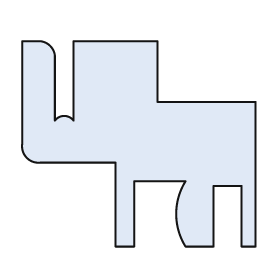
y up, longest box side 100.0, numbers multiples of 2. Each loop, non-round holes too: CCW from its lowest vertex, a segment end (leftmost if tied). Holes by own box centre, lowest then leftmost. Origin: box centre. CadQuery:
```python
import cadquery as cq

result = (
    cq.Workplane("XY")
    .moveTo(-10.0, -44.0)
    .lineTo(-2.0, -44.0)
    .lineTo(-2.0, -16.0)
    .lineTo(20.0, -16.0)
    .threePointArc((16.0, -30.0), (20.0, -44.0))
    .lineTo(32.0, -44.0)
    .lineTo(32.0, -18.0)
    .lineTo(44.0, -18.0)
    .lineTo(44.0, -44.0)
    .lineTo(50.0, -44.0)
    .lineTo(50.0, 18.0)
    .lineTo(8.0, 18.0)
    .lineTo(8.0, 44.0)
    .lineTo(-28.0, 44.0)
    .lineTo(-28.0, 10.0)
    .threePointArc((-32.0, 12.0), (-36.0, 10.0))
    .lineTo(-36.0, 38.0)
    .threePointArc((-38.0, 42.0), (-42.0, 44.0))
    .lineTo(-50.0, 44.0)
    .lineTo(-50.0, 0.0)
    .threePointArc((-48.0, -6.0), (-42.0, -8.0))
    .lineTo(-10.0, -8.0)
    .close()
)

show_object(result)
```